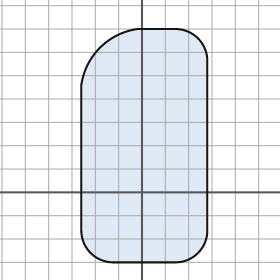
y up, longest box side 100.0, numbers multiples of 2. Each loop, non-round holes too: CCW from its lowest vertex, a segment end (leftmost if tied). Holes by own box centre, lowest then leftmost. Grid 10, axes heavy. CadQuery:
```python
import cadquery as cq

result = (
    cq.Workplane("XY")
    .moveTo(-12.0, -30.0)
    .lineTo(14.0, -30.0)
    .threePointArc((24.0, -26.0), (28.0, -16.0))
    .lineTo(28.0, 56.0)
    .threePointArc((24.0, 66.0), (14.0, 70.0))
    .lineTo(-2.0, 70.0)
    .threePointArc((-18.0, 62.0), (-26.0, 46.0))
    .lineTo(-26.0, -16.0)
    .threePointArc((-22.0, -26.0), (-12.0, -30.0))
    .close()
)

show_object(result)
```